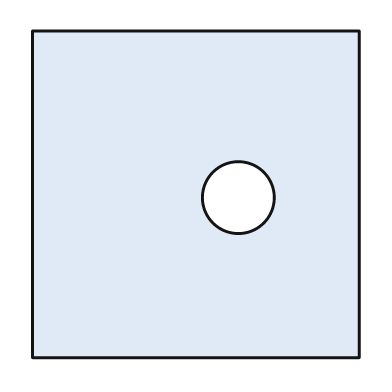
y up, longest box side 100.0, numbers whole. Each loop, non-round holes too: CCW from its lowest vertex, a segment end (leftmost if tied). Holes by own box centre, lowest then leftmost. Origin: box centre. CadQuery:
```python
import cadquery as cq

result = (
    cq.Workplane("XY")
    .moveTo(-50.0, -50.0)
    .lineTo(50.0, -50.0)
    .lineTo(50.0, 50.0)
    .lineTo(-50.0, 50.0)
    .close()
    .moveTo(13.0, -1.0)
    .circle(11.0)
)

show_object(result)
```